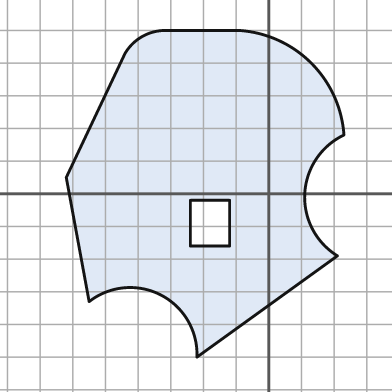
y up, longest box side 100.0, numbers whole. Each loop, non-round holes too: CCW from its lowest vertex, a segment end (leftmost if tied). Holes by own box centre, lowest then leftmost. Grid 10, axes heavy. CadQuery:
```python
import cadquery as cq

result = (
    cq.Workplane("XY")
    .moveTo(-22.0, -50.0)
    .lineTo(21.0, -19.0)
    .threePointArc((11.0, 0.0), (23.0, 18.0))
    .threePointArc((13.0, 40.0), (-9.0, 50.0))
    .lineTo(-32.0, 50.0)
    .threePointArc((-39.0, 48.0), (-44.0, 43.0))
    .lineTo(-62.0, 5.0)
    .lineTo(-55.0, -33.0)
    .threePointArc((-33.0, -31.0), (-22.0, -50.0))
    .close()
    .moveTo(-24.0, -16.0)
    .lineTo(-12.0, -16.0)
    .lineTo(-12.0, -2.0)
    .lineTo(-24.0, -2.0)
    .close()
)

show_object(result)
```